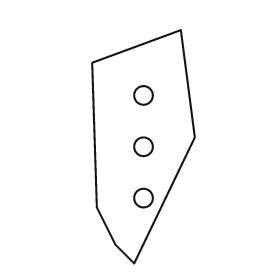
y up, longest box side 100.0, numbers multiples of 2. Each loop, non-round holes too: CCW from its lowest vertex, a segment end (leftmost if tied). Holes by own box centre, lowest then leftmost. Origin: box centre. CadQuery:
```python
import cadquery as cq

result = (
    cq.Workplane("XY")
    .moveTo(-4.0, -50.0)
    .lineTo(22.0, 4.0)
    .lineTo(16.0, 50.0)
    .lineTo(-22.0, 36.0)
    .lineTo(-20.0, -26.0)
    .lineTo(-12.0, -42.0)
    .close()
    .moveTo(0.0, -22.0)
    .circle(4.0)
    .moveTo(0.0, 0.0)
    .circle(4.0)
    .moveTo(0.0, 22.0)
    .circle(4.0)
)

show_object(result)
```